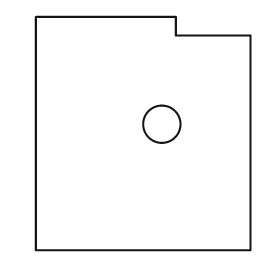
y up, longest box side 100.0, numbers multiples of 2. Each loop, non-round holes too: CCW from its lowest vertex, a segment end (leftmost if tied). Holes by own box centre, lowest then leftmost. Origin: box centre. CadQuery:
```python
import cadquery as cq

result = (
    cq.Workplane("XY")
    .moveTo(-46.0, -50.0)
    .lineTo(46.0, -50.0)
    .lineTo(46.0, 42.0)
    .lineTo(14.0, 42.0)
    .lineTo(14.0, 50.0)
    .lineTo(-46.0, 50.0)
    .close()
    .moveTo(8.0, 4.0)
    .circle(8.0)
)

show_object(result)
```